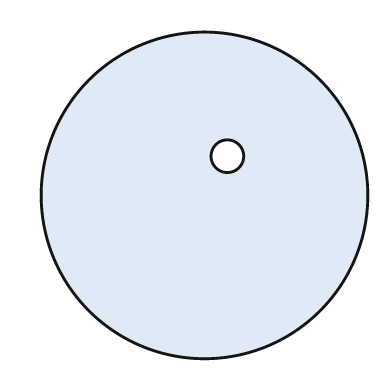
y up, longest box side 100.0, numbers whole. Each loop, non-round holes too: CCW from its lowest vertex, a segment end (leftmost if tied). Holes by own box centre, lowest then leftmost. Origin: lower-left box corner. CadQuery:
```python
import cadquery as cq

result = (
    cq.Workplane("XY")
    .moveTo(50.0, 50.0)
    .circle(50.0)
    .moveTo(57.0, 62.0)
    .circle(5.0)
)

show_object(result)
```